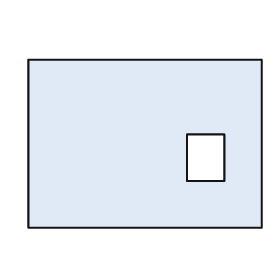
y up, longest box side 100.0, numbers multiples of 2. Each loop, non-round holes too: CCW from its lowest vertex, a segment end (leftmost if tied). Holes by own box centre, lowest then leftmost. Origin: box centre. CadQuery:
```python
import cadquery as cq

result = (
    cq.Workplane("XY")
    .moveTo(-50.0, -36.0)
    .lineTo(50.0, -36.0)
    .lineTo(50.0, 36.0)
    .lineTo(-50.0, 36.0)
    .close()
    .moveTo(18.0, -16.0)
    .lineTo(34.0, -16.0)
    .lineTo(34.0, 4.0)
    .lineTo(18.0, 4.0)
    .close()
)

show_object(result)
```